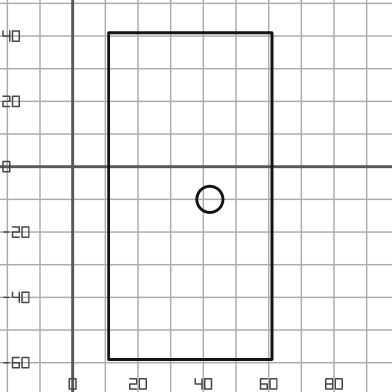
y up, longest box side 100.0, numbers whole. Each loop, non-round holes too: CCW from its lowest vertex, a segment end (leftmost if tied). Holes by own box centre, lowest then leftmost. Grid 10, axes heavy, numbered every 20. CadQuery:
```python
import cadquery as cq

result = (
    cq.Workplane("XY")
    .moveTo(11.0, -59.0)
    .lineTo(61.0, -59.0)
    .lineTo(61.0, 41.0)
    .lineTo(11.0, 41.0)
    .close()
    .moveTo(42.0, -10.0)
    .circle(4.0)
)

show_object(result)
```